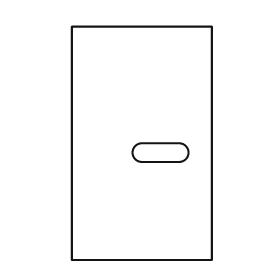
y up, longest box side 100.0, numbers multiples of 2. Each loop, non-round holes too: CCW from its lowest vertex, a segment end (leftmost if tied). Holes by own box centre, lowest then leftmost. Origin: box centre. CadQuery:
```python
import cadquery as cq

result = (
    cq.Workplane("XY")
    .moveTo(-30.0, -50.0)
    .lineTo(30.0, -50.0)
    .lineTo(30.0, 50.0)
    .lineTo(-30.0, 50.0)
    .close()
    .moveTo(0.0, -8.0)
    .lineTo(16.0, -8.0)
    .threePointArc((20.0, -4.0), (16.0, 0.0))
    .lineTo(0.0, 0.0)
    .threePointArc((-4.0, -4.0), (0.0, -8.0))
    .close()
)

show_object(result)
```